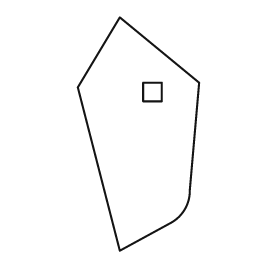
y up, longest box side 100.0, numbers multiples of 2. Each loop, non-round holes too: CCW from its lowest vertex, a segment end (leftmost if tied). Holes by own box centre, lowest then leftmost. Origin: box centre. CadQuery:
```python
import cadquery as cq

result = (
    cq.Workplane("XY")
    .moveTo(-8.0, -50.0)
    .lineTo(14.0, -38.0)
    .threePointArc((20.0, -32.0), (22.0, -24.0))
    .lineTo(26.0, 22.0)
    .lineTo(-8.0, 50.0)
    .lineTo(-26.0, 20.0)
    .close()
    .moveTo(2.0, 14.0)
    .lineTo(10.0, 14.0)
    .lineTo(10.0, 22.0)
    .lineTo(2.0, 22.0)
    .close()
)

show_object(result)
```